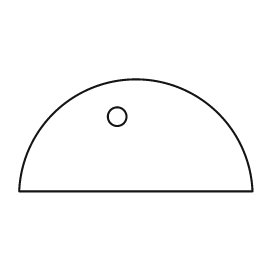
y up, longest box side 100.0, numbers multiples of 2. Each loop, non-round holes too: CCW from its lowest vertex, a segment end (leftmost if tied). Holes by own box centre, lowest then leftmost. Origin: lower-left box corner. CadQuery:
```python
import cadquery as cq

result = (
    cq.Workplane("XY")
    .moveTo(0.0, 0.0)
    .lineTo(100.0, 0.0)
    .threePointArc((50.0, 48.0), (0.0, 0.0))
    .close()
    .moveTo(42.0, 32.0)
    .circle(4.0)
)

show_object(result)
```